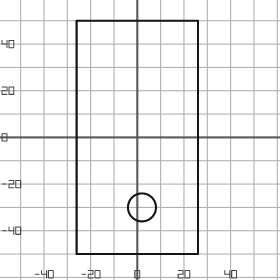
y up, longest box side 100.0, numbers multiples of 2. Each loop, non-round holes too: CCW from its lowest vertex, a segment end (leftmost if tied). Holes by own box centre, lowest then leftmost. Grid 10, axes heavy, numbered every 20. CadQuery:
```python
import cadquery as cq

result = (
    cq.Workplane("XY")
    .moveTo(-26.0, -50.0)
    .lineTo(26.0, -50.0)
    .lineTo(26.0, 50.0)
    .lineTo(-26.0, 50.0)
    .close()
    .moveTo(2.0, -30.0)
    .circle(6.0)
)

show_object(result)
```